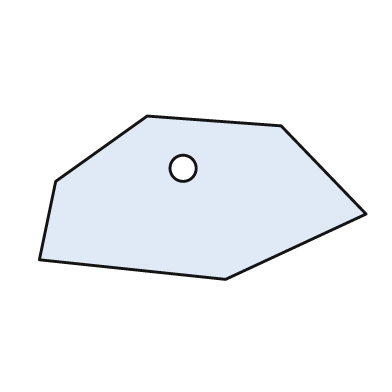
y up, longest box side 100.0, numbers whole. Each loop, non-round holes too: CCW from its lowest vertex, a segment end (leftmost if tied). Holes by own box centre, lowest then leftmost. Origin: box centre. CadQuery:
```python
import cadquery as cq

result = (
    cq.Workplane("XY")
    .moveTo(7.0, -25.0)
    .lineTo(50.0, -5.0)
    .lineTo(24.0, 22.0)
    .lineTo(-17.0, 25.0)
    .lineTo(-45.0, 5.0)
    .lineTo(-50.0, -19.0)
    .close()
    .moveTo(-6.0, 9.0)
    .circle(4.0)
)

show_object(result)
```